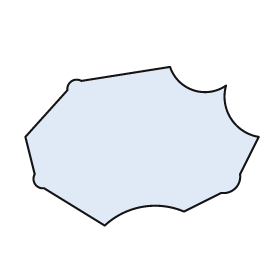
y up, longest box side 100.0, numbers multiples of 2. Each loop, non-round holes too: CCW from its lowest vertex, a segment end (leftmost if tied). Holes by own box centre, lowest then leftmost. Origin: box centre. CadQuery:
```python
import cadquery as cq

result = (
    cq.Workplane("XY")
    .moveTo(-16.0, -34.0)
    .threePointArc((0.0, -26.0), (18.0, -28.0))
    .lineTo(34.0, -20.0)
    .threePointArc((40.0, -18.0), (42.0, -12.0))
    .lineTo(50.0, 4.0)
    .threePointArc((38.0, 12.0), (36.0, 26.0))
    .threePointArc((22.0, 24.0), (12.0, 34.0))
    .lineTo(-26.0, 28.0)
    .threePointArc((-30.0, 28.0), (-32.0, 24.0))
    .lineTo(-50.0, 4.0)
    .lineTo(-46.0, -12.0)
    .threePointArc((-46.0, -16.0), (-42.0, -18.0))
    .close()
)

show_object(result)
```